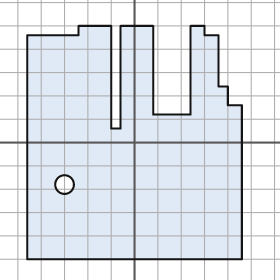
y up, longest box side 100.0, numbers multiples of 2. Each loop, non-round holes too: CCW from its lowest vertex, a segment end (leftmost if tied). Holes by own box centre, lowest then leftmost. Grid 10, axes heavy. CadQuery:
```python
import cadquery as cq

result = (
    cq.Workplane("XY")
    .moveTo(-46.0, -50.0)
    .lineTo(46.0, -50.0)
    .lineTo(46.0, 16.0)
    .lineTo(40.0, 16.0)
    .lineTo(40.0, 24.0)
    .lineTo(36.0, 24.0)
    .lineTo(36.0, 46.0)
    .lineTo(30.0, 46.0)
    .lineTo(30.0, 50.0)
    .lineTo(24.0, 50.0)
    .lineTo(24.0, 12.0)
    .lineTo(8.0, 12.0)
    .lineTo(8.0, 50.0)
    .lineTo(-6.0, 50.0)
    .lineTo(-6.0, 6.0)
    .lineTo(-10.0, 6.0)
    .lineTo(-10.0, 50.0)
    .lineTo(-24.0, 50.0)
    .lineTo(-24.0, 46.0)
    .lineTo(-46.0, 46.0)
    .close()
    .moveTo(-30.0, -18.0)
    .circle(4.0)
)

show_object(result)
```